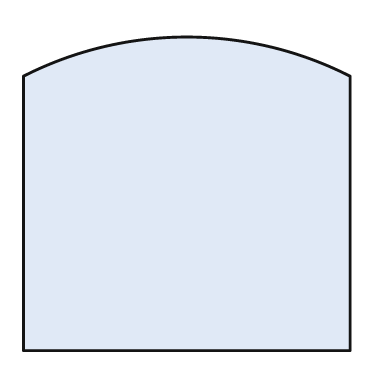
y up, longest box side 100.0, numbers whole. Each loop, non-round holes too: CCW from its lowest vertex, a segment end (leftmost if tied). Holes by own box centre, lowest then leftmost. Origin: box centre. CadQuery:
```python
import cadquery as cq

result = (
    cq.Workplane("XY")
    .moveTo(-50.0, -48.0)
    .lineTo(50.0, -48.0)
    .lineTo(50.0, 36.0)
    .threePointArc((0.0, 48.0), (-50.0, 36.0))
    .close()
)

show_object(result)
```